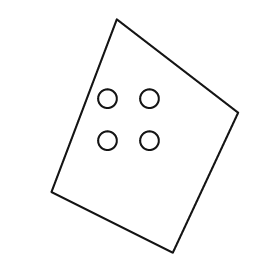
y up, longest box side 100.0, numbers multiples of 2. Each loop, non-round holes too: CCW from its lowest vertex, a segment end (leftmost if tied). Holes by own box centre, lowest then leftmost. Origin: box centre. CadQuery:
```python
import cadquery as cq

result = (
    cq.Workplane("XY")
    .moveTo(12.0, -50.0)
    .lineTo(40.0, 10.0)
    .lineTo(-12.0, 50.0)
    .lineTo(-40.0, -24.0)
    .close()
    .moveTo(-16.0, -2.0)
    .circle(4.0)
    .moveTo(2.0, -2.0)
    .circle(4.0)
    .moveTo(-16.0, 16.0)
    .circle(4.0)
    .moveTo(2.0, 16.0)
    .circle(4.0)
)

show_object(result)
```